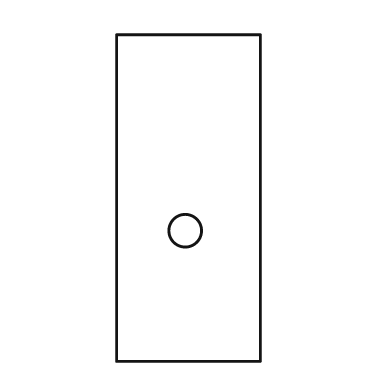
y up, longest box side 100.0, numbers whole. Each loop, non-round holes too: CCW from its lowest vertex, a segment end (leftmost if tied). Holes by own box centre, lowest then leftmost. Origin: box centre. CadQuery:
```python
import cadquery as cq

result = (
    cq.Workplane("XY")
    .moveTo(-22.0, -50.0)
    .lineTo(22.0, -50.0)
    .lineTo(22.0, 50.0)
    .lineTo(-22.0, 50.0)
    .close()
    .moveTo(-1.0, -10.0)
    .circle(5.0)
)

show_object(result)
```